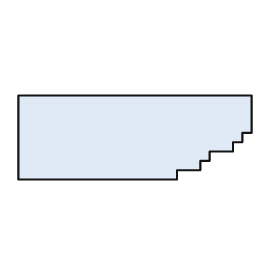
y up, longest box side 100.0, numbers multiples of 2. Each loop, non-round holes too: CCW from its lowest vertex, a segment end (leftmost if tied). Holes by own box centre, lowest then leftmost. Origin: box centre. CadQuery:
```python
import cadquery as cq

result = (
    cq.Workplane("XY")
    .moveTo(-50.0, -18.0)
    .lineTo(18.0, -18.0)
    .lineTo(18.0, -14.0)
    .lineTo(28.0, -14.0)
    .lineTo(28.0, -10.0)
    .lineTo(32.0, -10.0)
    .lineTo(32.0, -6.0)
    .lineTo(42.0, -6.0)
    .lineTo(42.0, -2.0)
    .lineTo(46.0, -2.0)
    .lineTo(46.0, 2.0)
    .lineTo(50.0, 2.0)
    .lineTo(50.0, 18.0)
    .lineTo(-50.0, 18.0)
    .close()
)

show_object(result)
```